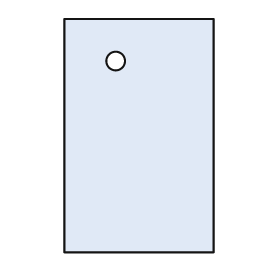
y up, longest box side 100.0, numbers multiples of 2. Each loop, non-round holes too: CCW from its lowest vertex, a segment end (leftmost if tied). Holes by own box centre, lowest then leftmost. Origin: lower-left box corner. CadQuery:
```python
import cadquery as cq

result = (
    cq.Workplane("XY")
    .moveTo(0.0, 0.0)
    .lineTo(64.0, 0.0)
    .lineTo(64.0, 100.0)
    .lineTo(0.0, 100.0)
    .close()
    .moveTo(22.0, 82.0)
    .circle(4.0)
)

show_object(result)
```